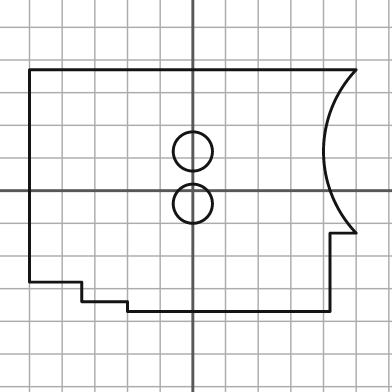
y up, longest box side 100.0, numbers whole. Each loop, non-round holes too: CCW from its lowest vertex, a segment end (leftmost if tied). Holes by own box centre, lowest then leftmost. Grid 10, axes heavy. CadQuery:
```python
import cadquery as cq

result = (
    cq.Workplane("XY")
    .moveTo(-20.0, -37.0)
    .lineTo(42.0, -37.0)
    .lineTo(42.0, -13.0)
    .lineTo(50.0, -13.0)
    .threePointArc((40.0, 12.0), (50.0, 37.0))
    .lineTo(-50.0, 37.0)
    .lineTo(-50.0, -28.0)
    .lineTo(-34.0, -28.0)
    .lineTo(-34.0, -34.0)
    .lineTo(-20.0, -34.0)
    .close()
    .moveTo(0.0, -4.0)
    .circle(6.0)
    .moveTo(0.0, 12.0)
    .circle(6.0)
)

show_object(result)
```